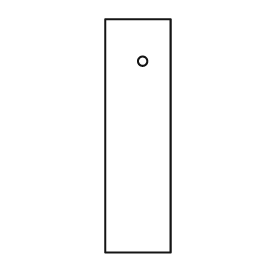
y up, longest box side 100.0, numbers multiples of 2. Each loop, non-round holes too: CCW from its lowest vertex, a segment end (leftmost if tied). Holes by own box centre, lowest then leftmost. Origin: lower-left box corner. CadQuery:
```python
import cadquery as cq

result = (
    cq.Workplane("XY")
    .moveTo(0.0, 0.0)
    .lineTo(28.0, 0.0)
    .lineTo(28.0, 100.0)
    .lineTo(0.0, 100.0)
    .close()
    .moveTo(16.0, 82.0)
    .circle(2.0)
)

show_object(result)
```